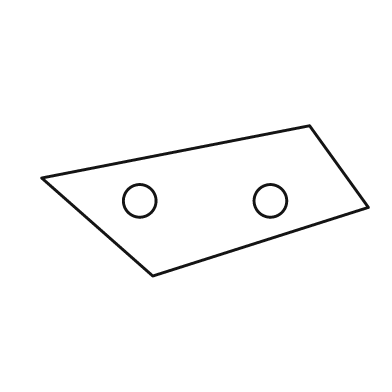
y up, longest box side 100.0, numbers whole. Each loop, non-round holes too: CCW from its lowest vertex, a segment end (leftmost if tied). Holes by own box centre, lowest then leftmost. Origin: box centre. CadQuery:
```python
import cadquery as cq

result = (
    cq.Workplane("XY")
    .moveTo(-16.0, -23.0)
    .lineTo(50.0, -2.0)
    .lineTo(32.0, 23.0)
    .lineTo(-50.0, 7.0)
    .close()
    .moveTo(-20.0, 0.0)
    .circle(5.0)
    .moveTo(20.0, 0.0)
    .circle(5.0)
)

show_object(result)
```